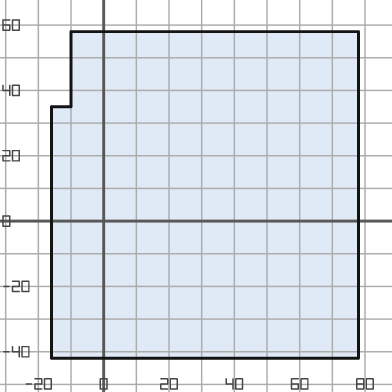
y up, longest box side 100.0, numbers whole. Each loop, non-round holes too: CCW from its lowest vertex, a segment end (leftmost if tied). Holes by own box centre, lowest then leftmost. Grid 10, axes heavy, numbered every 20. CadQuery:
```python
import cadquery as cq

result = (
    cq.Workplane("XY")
    .moveTo(-16.0, -42.0)
    .lineTo(78.0, -42.0)
    .lineTo(78.0, 58.0)
    .lineTo(-10.0, 58.0)
    .lineTo(-10.0, 35.0)
    .lineTo(-16.0, 35.0)
    .close()
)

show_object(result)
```